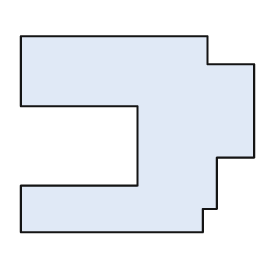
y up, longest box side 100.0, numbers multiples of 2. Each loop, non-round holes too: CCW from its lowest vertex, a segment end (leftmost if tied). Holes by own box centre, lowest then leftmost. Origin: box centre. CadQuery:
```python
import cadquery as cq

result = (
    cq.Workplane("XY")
    .moveTo(-50.0, -42.0)
    .lineTo(28.0, -42.0)
    .lineTo(28.0, -32.0)
    .lineTo(34.0, -32.0)
    .lineTo(34.0, -10.0)
    .lineTo(50.0, -10.0)
    .lineTo(50.0, 30.0)
    .lineTo(30.0, 30.0)
    .lineTo(30.0, 42.0)
    .lineTo(-50.0, 42.0)
    .lineTo(-50.0, 12.0)
    .lineTo(0.0, 12.0)
    .lineTo(0.0, -22.0)
    .lineTo(-50.0, -22.0)
    .close()
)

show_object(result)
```